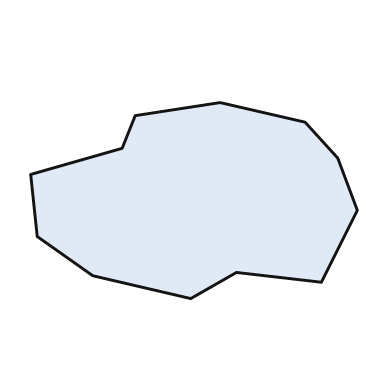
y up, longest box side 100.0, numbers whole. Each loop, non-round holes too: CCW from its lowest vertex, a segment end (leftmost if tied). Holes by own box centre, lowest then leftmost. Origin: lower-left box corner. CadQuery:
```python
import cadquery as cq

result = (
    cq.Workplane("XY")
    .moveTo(49.0, 0.0)
    .lineTo(63.0, 8.0)
    .lineTo(89.0, 5.0)
    .lineTo(100.0, 27.0)
    .lineTo(94.0, 43.0)
    .lineTo(84.0, 54.0)
    .lineTo(58.0, 60.0)
    .lineTo(32.0, 56.0)
    .lineTo(28.0, 46.0)
    .lineTo(0.0, 38.0)
    .lineTo(2.0, 19.0)
    .lineTo(19.0, 7.0)
    .close()
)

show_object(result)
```